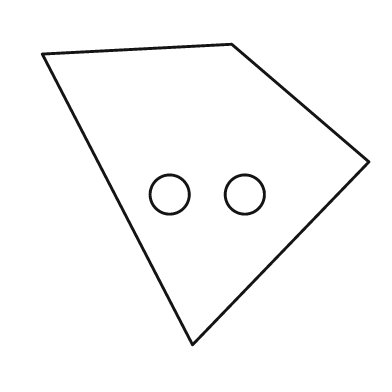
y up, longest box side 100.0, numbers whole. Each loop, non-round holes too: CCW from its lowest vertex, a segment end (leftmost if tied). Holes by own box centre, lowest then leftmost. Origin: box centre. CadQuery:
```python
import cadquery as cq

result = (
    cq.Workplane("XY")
    .moveTo(-4.0, -46.0)
    .lineTo(50.0, 10.0)
    .lineTo(8.0, 46.0)
    .lineTo(-50.0, 43.0)
    .close()
    .moveTo(-11.0, 0.0)
    .circle(6.0)
    .moveTo(12.0, 0.0)
    .circle(6.0)
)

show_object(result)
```